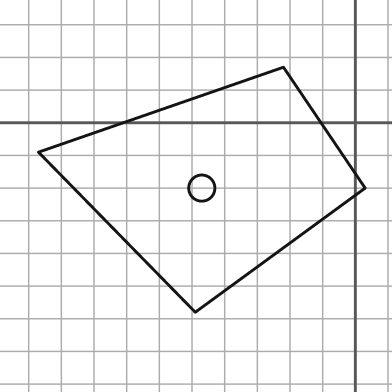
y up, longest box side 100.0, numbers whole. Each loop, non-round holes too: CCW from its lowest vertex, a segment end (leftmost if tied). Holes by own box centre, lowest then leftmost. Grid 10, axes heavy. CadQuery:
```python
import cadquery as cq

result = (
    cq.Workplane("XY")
    .moveTo(-49.0, -58.0)
    .lineTo(3.0, -20.0)
    .lineTo(-22.0, 17.0)
    .lineTo(-97.0, -9.0)
    .close()
    .moveTo(-47.0, -20.0)
    .circle(4.0)
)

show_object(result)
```